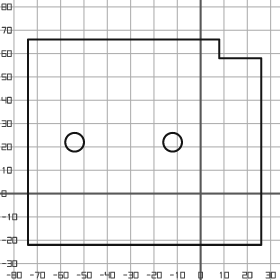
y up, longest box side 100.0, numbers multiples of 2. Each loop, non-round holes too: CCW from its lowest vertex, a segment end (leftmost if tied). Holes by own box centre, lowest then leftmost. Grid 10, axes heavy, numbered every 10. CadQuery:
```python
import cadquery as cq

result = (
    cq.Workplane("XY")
    .moveTo(-74.0, -22.0)
    .lineTo(26.0, -22.0)
    .lineTo(26.0, 58.0)
    .lineTo(8.0, 58.0)
    .lineTo(8.0, 66.0)
    .lineTo(-74.0, 66.0)
    .close()
    .moveTo(-54.0, 22.0)
    .circle(4.0)
    .moveTo(-12.0, 22.0)
    .circle(4.0)
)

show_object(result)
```